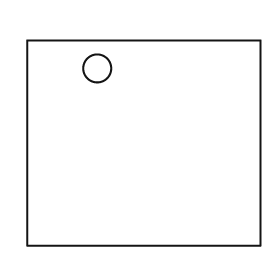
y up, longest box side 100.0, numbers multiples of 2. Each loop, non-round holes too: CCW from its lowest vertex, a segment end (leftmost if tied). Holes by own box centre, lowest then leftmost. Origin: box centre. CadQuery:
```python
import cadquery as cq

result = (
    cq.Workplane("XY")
    .moveTo(-50.0, -44.0)
    .lineTo(50.0, -44.0)
    .lineTo(50.0, 44.0)
    .lineTo(-50.0, 44.0)
    .close()
    .moveTo(-20.0, 32.0)
    .circle(6.0)
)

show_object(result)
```